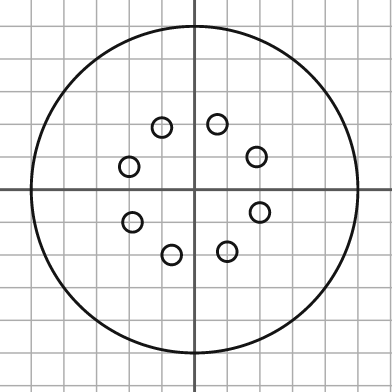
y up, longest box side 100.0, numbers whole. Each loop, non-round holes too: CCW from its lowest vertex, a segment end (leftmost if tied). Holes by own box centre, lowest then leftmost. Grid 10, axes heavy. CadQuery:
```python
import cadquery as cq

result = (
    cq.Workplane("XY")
    .moveTo(0.0, 0.0)
    .circle(50.0)
    .moveTo(-7.0, -20.0)
    .circle(3.0)
    .moveTo(10.0, -19.0)
    .circle(3.0)
    .moveTo(-19.0, -10.0)
    .circle(3.0)
    .moveTo(20.0, -7.0)
    .circle(3.0)
    .moveTo(-20.0, 7.0)
    .circle(3.0)
    .moveTo(19.0, 10.0)
    .circle(3.0)
    .moveTo(-10.0, 19.0)
    .circle(3.0)
    .moveTo(7.0, 20.0)
    .circle(3.0)
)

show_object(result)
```